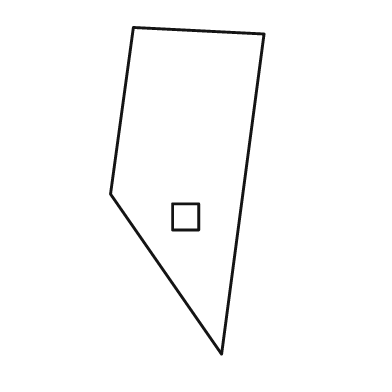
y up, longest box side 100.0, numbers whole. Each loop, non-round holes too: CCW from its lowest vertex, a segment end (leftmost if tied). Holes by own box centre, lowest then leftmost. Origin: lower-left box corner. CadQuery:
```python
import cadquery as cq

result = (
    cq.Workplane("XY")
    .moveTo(34.0, 0.0)
    .lineTo(47.0, 98.0)
    .lineTo(7.0, 100.0)
    .lineTo(0.0, 49.0)
    .close()
    .moveTo(19.0, 38.0)
    .lineTo(27.0, 38.0)
    .lineTo(27.0, 46.0)
    .lineTo(19.0, 46.0)
    .close()
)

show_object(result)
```